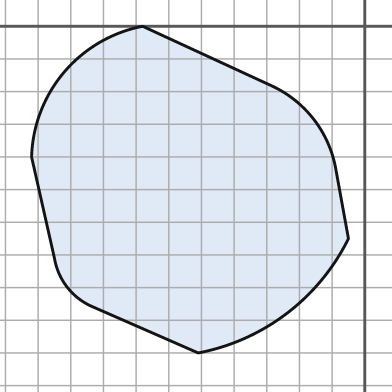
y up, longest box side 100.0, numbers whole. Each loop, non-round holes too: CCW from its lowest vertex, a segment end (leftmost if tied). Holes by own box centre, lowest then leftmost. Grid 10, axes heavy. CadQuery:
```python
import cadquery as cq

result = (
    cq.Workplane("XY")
    .moveTo(-51.0, -100.0)
    .threePointArc((-24.0, -88.0), (-5.0, -65.0))
    .lineTo(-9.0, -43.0)
    .threePointArc((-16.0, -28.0), (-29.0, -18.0))
    .lineTo(-68.0, 0.0)
    .threePointArc((-92.0, -14.0), (-102.0, -40.0))
    .lineTo(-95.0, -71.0)
    .threePointArc((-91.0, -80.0), (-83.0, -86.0))
    .close()
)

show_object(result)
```